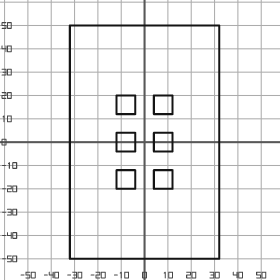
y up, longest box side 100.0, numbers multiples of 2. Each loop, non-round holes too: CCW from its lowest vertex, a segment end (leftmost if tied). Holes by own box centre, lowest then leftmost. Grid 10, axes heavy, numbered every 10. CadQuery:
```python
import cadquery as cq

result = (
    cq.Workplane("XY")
    .moveTo(-32.0, -50.0)
    .lineTo(32.0, -50.0)
    .lineTo(32.0, 50.0)
    .lineTo(-32.0, 50.0)
    .close()
    .moveTo(-12.0, -20.0)
    .lineTo(-4.0, -20.0)
    .lineTo(-4.0, -12.0)
    .lineTo(-12.0, -12.0)
    .close()
    .moveTo(4.0, -20.0)
    .lineTo(12.0, -20.0)
    .lineTo(12.0, -12.0)
    .lineTo(4.0, -12.0)
    .close()
    .moveTo(-12.0, -4.0)
    .lineTo(-4.0, -4.0)
    .lineTo(-4.0, 4.0)
    .lineTo(-12.0, 4.0)
    .close()
    .moveTo(4.0, -4.0)
    .lineTo(12.0, -4.0)
    .lineTo(12.0, 4.0)
    .lineTo(4.0, 4.0)
    .close()
    .moveTo(-12.0, 12.0)
    .lineTo(-4.0, 12.0)
    .lineTo(-4.0, 20.0)
    .lineTo(-12.0, 20.0)
    .close()
    .moveTo(4.0, 12.0)
    .lineTo(12.0, 12.0)
    .lineTo(12.0, 20.0)
    .lineTo(4.0, 20.0)
    .close()
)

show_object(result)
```